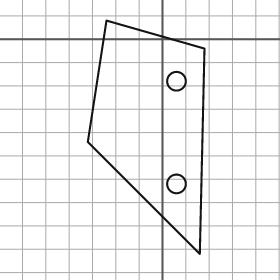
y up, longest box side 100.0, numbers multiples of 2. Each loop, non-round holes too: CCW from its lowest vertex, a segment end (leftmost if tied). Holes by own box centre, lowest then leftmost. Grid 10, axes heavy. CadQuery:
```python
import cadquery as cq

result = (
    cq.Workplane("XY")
    .moveTo(16.0, -92.0)
    .lineTo(18.0, -4.0)
    .lineTo(-24.0, 8.0)
    .lineTo(-32.0, -44.0)
    .close()
    .moveTo(6.0, -62.0)
    .circle(4.0)
    .moveTo(6.0, -18.0)
    .circle(4.0)
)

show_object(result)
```